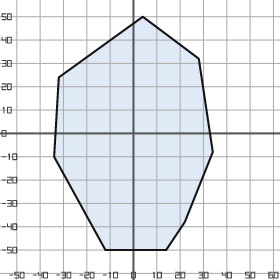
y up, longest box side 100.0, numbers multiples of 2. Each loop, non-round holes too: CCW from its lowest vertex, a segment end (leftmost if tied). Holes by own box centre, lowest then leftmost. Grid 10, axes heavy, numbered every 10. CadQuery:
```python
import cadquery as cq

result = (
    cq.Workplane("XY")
    .moveTo(-12.0, -50.0)
    .lineTo(14.0, -50.0)
    .lineTo(22.0, -38.0)
    .lineTo(34.0, -8.0)
    .lineTo(28.0, 32.0)
    .lineTo(4.0, 50.0)
    .lineTo(-32.0, 24.0)
    .lineTo(-34.0, -10.0)
    .close()
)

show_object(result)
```